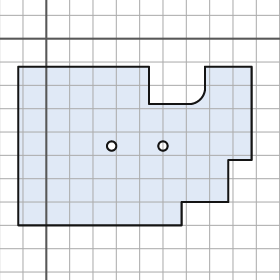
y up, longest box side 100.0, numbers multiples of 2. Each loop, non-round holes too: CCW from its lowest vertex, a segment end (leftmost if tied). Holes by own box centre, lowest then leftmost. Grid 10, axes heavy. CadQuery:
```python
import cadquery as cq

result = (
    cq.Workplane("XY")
    .moveTo(-12.0, -80.0)
    .lineTo(58.0, -80.0)
    .lineTo(58.0, -70.0)
    .lineTo(78.0, -70.0)
    .lineTo(78.0, -52.0)
    .lineTo(88.0, -52.0)
    .lineTo(88.0, -12.0)
    .lineTo(68.0, -12.0)
    .lineTo(68.0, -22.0)
    .threePointArc((66.0, -26.0), (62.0, -28.0))
    .lineTo(44.0, -28.0)
    .lineTo(44.0, -12.0)
    .lineTo(-12.0, -12.0)
    .close()
    .moveTo(28.0, -46.0)
    .circle(2.0)
    .moveTo(50.0, -46.0)
    .circle(2.0)
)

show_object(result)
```